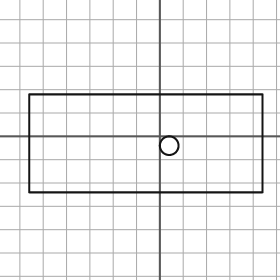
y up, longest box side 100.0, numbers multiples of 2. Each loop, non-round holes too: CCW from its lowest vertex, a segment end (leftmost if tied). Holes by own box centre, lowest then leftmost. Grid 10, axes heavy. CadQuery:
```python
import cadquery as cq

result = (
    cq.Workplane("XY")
    .moveTo(-56.0, -24.0)
    .lineTo(44.0, -24.0)
    .lineTo(44.0, 18.0)
    .lineTo(-56.0, 18.0)
    .close()
    .moveTo(4.0, -4.0)
    .circle(4.0)
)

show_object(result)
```